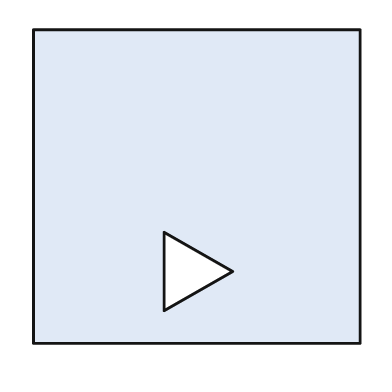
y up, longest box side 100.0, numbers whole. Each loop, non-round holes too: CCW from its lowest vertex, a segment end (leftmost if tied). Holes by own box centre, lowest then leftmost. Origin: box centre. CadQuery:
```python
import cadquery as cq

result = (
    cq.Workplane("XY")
    .moveTo(-50.0, -48.0)
    .lineTo(50.0, -48.0)
    .lineTo(50.0, 48.0)
    .lineTo(-50.0, 48.0)
    .close()
    .moveTo(-10.0, -38.0)
    .lineTo(11.0, -26.0)
    .lineTo(-10.0, -14.0)
    .close()
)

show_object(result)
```